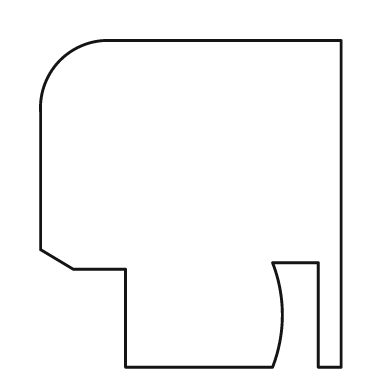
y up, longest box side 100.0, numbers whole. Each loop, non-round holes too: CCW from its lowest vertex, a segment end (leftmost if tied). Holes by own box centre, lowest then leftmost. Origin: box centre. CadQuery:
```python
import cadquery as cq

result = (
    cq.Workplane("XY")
    .moveTo(-20.0, -50.0)
    .lineTo(25.0, -50.0)
    .threePointArc((28.0, -34.0), (25.0, -18.0))
    .lineTo(39.0, -18.0)
    .lineTo(39.0, -50.0)
    .lineTo(46.0, -50.0)
    .lineTo(46.0, 50.0)
    .lineTo(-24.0, 50.0)
    .threePointArc((-40.0, 44.0), (-46.0, 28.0))
    .lineTo(-46.0, -14.0)
    .lineTo(-36.0, -20.0)
    .lineTo(-20.0, -20.0)
    .close()
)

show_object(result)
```